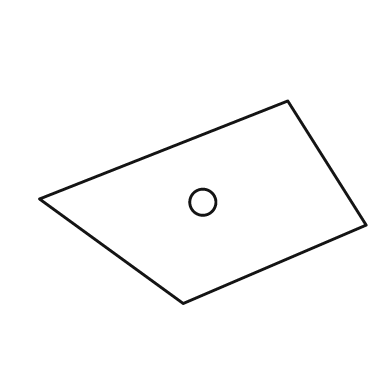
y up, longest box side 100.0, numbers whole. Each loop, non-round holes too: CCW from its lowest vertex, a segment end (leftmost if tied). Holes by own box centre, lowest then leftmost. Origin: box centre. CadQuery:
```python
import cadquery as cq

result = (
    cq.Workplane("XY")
    .moveTo(-6.0, -31.0)
    .lineTo(50.0, -7.0)
    .lineTo(26.0, 31.0)
    .lineTo(-50.0, 1.0)
    .close()
    .moveTo(0.0, 0.0)
    .circle(4.0)
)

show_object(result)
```